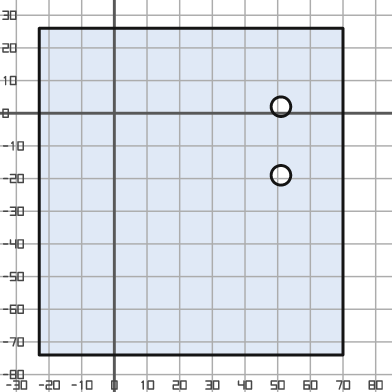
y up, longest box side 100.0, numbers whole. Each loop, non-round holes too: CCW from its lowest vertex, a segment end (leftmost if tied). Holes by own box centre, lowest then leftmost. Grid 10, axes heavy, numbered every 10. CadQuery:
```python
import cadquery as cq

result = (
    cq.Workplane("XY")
    .moveTo(-23.0, -74.0)
    .lineTo(70.0, -74.0)
    .lineTo(70.0, 26.0)
    .lineTo(-23.0, 26.0)
    .close()
    .moveTo(51.0, -19.0)
    .circle(3.0)
    .moveTo(51.0, 2.0)
    .circle(3.0)
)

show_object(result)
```